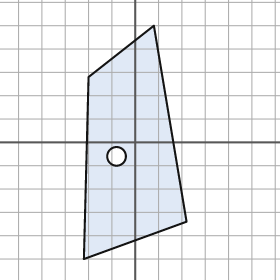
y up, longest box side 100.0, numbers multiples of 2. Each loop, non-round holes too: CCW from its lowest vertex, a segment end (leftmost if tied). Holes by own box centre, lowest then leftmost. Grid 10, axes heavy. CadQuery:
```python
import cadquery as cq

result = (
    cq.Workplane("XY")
    .moveTo(-22.0, -50.0)
    .lineTo(22.0, -34.0)
    .lineTo(8.0, 50.0)
    .lineTo(-20.0, 28.0)
    .close()
    .moveTo(-8.0, -6.0)
    .circle(4.0)
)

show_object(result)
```